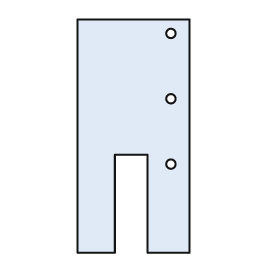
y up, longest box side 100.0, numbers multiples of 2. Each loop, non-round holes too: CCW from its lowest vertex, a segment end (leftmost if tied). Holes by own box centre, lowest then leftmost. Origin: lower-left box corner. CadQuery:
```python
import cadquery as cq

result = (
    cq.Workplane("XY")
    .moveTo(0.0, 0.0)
    .lineTo(16.0, 0.0)
    .lineTo(16.0, 42.0)
    .lineTo(30.0, 42.0)
    .lineTo(30.0, 0.0)
    .lineTo(48.0, 0.0)
    .lineTo(48.0, 100.0)
    .lineTo(0.0, 100.0)
    .close()
    .moveTo(40.0, 38.0)
    .circle(2.0)
    .moveTo(40.0, 66.0)
    .circle(2.0)
    .moveTo(40.0, 94.0)
    .circle(2.0)
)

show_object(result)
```